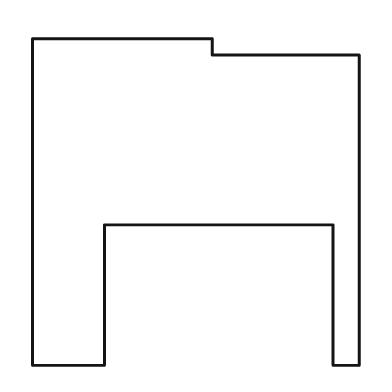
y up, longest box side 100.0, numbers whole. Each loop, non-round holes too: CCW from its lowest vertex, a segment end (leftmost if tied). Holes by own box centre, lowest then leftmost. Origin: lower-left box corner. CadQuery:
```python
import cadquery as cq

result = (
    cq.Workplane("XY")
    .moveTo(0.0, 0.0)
    .lineTo(22.0, 0.0)
    .lineTo(22.0, 43.0)
    .lineTo(92.0, 43.0)
    .lineTo(92.0, 0.0)
    .lineTo(100.0, 0.0)
    .lineTo(100.0, 95.0)
    .lineTo(55.0, 95.0)
    .lineTo(55.0, 100.0)
    .lineTo(0.0, 100.0)
    .close()
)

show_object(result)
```